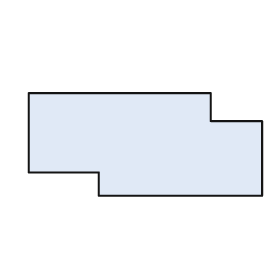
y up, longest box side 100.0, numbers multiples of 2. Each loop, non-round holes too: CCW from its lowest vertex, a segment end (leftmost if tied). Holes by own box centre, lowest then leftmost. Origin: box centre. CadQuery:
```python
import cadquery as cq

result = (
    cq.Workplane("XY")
    .moveTo(-20.0, -22.0)
    .lineTo(50.0, -22.0)
    .lineTo(50.0, 10.0)
    .lineTo(28.0, 10.0)
    .lineTo(28.0, 22.0)
    .lineTo(-50.0, 22.0)
    .lineTo(-50.0, -12.0)
    .lineTo(-20.0, -12.0)
    .close()
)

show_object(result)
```